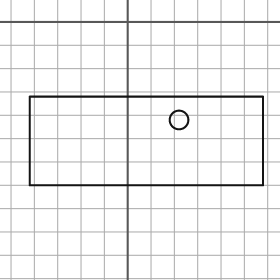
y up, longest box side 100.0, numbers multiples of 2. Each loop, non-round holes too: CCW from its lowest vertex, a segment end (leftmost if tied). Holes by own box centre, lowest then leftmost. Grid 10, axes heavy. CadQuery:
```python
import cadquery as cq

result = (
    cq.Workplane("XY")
    .moveTo(-42.0, -70.0)
    .lineTo(58.0, -70.0)
    .lineTo(58.0, -32.0)
    .lineTo(-42.0, -32.0)
    .close()
    .moveTo(22.0, -42.0)
    .circle(4.0)
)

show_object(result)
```